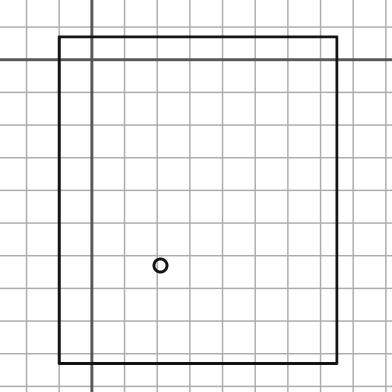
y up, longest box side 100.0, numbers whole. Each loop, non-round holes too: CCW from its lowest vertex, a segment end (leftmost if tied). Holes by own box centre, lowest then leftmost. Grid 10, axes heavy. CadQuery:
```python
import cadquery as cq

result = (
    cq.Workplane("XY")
    .moveTo(-10.0, -93.0)
    .lineTo(75.0, -93.0)
    .lineTo(75.0, 7.0)
    .lineTo(-10.0, 7.0)
    .close()
    .moveTo(21.0, -63.0)
    .circle(2.0)
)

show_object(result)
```